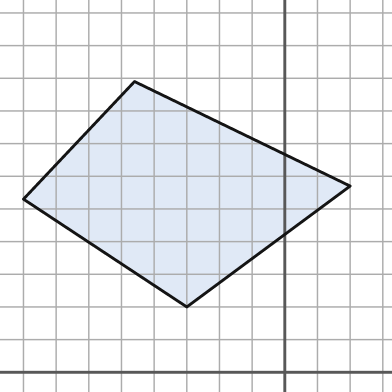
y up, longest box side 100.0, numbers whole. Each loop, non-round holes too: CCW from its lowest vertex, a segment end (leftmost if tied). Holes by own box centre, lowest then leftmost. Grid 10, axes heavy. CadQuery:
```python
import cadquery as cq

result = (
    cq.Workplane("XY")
    .moveTo(-30.0, 20.0)
    .lineTo(20.0, 57.0)
    .lineTo(-46.0, 89.0)
    .lineTo(-80.0, 53.0)
    .close()
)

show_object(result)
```